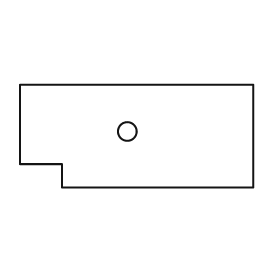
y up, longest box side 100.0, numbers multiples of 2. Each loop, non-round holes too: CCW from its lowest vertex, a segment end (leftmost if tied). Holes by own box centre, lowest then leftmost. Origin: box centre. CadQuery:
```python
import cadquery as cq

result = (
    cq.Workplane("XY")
    .moveTo(-32.0, -22.0)
    .lineTo(50.0, -22.0)
    .lineTo(50.0, 22.0)
    .lineTo(-50.0, 22.0)
    .lineTo(-50.0, -12.0)
    .lineTo(-32.0, -12.0)
    .close()
    .moveTo(-4.0, 2.0)
    .circle(4.0)
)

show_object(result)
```